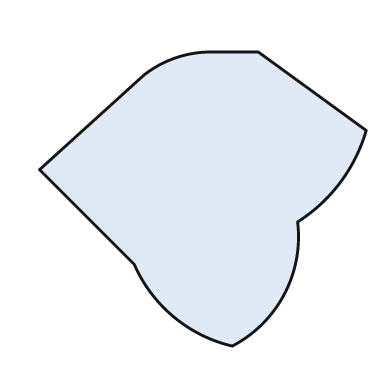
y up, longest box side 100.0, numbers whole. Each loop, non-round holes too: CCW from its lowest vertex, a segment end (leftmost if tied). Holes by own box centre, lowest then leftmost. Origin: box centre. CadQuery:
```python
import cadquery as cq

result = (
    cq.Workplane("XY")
    .moveTo(9.0, -45.0)
    .threePointArc((25.0, -29.0), (29.0, -7.0))
    .threePointArc((42.0, 5.0), (50.0, 21.0))
    .lineTo(17.0, 45.0)
    .lineTo(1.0, 45.0)
    .threePointArc((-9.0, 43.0), (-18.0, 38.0))
    .lineTo(-50.0, 9.0)
    .lineTo(-21.0, -20.0)
    .threePointArc((-9.0, -36.0), (9.0, -45.0))
    .close()
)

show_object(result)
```